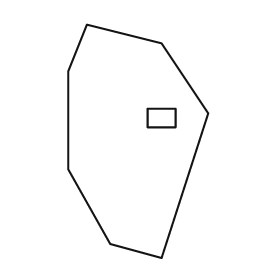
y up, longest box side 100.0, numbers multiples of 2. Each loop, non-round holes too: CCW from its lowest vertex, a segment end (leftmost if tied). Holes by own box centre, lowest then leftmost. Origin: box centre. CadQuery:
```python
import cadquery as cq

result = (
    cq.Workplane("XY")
    .moveTo(10.0, -50.0)
    .lineTo(30.0, 12.0)
    .lineTo(10.0, 42.0)
    .lineTo(-22.0, 50.0)
    .lineTo(-30.0, 30.0)
    .lineTo(-30.0, -12.0)
    .lineTo(-12.0, -44.0)
    .close()
    .moveTo(4.0, 6.0)
    .lineTo(16.0, 6.0)
    .lineTo(16.0, 14.0)
    .lineTo(4.0, 14.0)
    .close()
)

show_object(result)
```